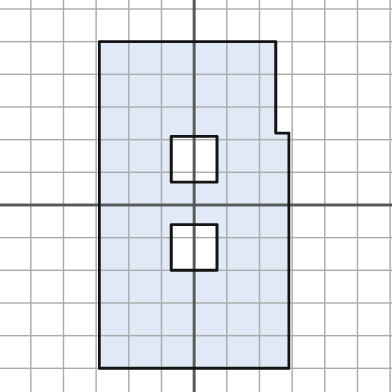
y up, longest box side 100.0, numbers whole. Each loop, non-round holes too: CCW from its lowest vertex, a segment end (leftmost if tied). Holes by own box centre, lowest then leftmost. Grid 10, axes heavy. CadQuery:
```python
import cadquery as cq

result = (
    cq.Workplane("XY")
    .moveTo(-29.0, -50.0)
    .lineTo(29.0, -50.0)
    .lineTo(29.0, 22.0)
    .lineTo(25.0, 22.0)
    .lineTo(25.0, 50.0)
    .lineTo(-29.0, 50.0)
    .close()
    .moveTo(-7.0, -20.0)
    .lineTo(7.0, -20.0)
    .lineTo(7.0, -6.0)
    .lineTo(-7.0, -6.0)
    .close()
    .moveTo(-7.0, 7.0)
    .lineTo(7.0, 7.0)
    .lineTo(7.0, 21.0)
    .lineTo(-7.0, 21.0)
    .close()
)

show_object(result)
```